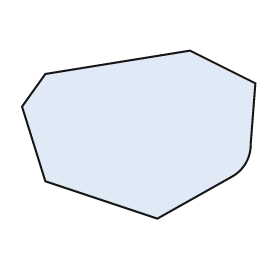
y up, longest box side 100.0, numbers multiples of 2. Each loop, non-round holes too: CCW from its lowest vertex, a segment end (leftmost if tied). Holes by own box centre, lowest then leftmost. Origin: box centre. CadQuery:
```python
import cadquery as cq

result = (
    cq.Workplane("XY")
    .moveTo(8.0, -36.0)
    .lineTo(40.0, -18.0)
    .threePointArc((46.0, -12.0), (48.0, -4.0))
    .lineTo(50.0, 22.0)
    .lineTo(22.0, 36.0)
    .lineTo(-40.0, 26.0)
    .lineTo(-50.0, 12.0)
    .lineTo(-40.0, -20.0)
    .close()
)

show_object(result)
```